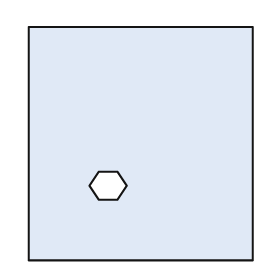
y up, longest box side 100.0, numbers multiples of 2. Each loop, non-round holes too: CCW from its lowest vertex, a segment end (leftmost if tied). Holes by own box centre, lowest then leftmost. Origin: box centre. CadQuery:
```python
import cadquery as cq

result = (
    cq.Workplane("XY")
    .moveTo(-48.0, -50.0)
    .lineTo(48.0, -50.0)
    .lineTo(48.0, 50.0)
    .lineTo(-48.0, 50.0)
    .close()
    .moveTo(-18.0, -24.0)
    .lineTo(-10.0, -24.0)
    .lineTo(-6.0, -18.0)
    .lineTo(-10.0, -12.0)
    .lineTo(-18.0, -12.0)
    .lineTo(-22.0, -18.0)
    .close()
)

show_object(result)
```